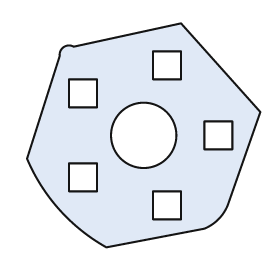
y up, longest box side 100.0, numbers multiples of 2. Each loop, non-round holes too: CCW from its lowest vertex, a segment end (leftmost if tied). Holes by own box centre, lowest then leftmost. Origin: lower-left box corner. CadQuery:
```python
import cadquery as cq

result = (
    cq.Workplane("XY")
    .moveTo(34.0, 0.0)
    .lineTo(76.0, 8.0)
    .threePointArc((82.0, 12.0), (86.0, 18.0))
    .lineTo(100.0, 58.0)
    .lineTo(66.0, 96.0)
    .lineTo(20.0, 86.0)
    .threePointArc((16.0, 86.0), (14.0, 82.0))
    .lineTo(0.0, 38.0)
    .threePointArc((14.0, 16.0), (34.0, 0.0))
    .close()
    .moveTo(54.0, 12.0)
    .lineTo(66.0, 12.0)
    .lineTo(66.0, 24.0)
    .lineTo(54.0, 24.0)
    .close()
    .moveTo(18.0, 24.0)
    .lineTo(30.0, 24.0)
    .lineTo(30.0, 36.0)
    .lineTo(18.0, 36.0)
    .close()
    .moveTo(50.0, 48.0)
    .circle(14.0)
    .moveTo(76.0, 42.0)
    .lineTo(88.0, 42.0)
    .lineTo(88.0, 54.0)
    .lineTo(76.0, 54.0)
    .close()
    .moveTo(18.0, 60.0)
    .lineTo(30.0, 60.0)
    .lineTo(30.0, 72.0)
    .lineTo(18.0, 72.0)
    .close()
    .moveTo(54.0, 72.0)
    .lineTo(66.0, 72.0)
    .lineTo(66.0, 84.0)
    .lineTo(54.0, 84.0)
    .close()
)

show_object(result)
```